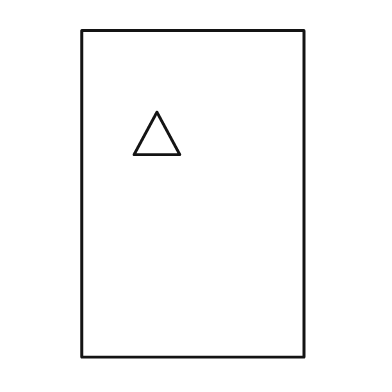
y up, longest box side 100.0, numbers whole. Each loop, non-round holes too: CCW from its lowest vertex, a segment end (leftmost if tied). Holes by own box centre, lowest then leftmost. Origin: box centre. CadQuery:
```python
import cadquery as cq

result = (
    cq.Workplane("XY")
    .moveTo(-34.0, -50.0)
    .lineTo(34.0, -50.0)
    .lineTo(34.0, 50.0)
    .lineTo(-34.0, 50.0)
    .close()
    .moveTo(-18.0, 12.0)
    .lineTo(-4.0, 12.0)
    .lineTo(-11.0, 25.0)
    .close()
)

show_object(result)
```